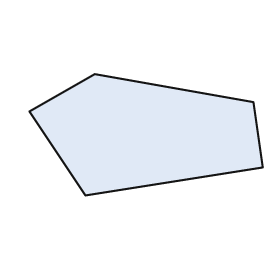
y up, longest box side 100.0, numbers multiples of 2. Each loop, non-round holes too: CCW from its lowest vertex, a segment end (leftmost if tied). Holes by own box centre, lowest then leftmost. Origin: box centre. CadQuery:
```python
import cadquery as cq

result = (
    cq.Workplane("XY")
    .moveTo(-26.0, -26.0)
    .lineTo(50.0, -14.0)
    .lineTo(46.0, 14.0)
    .lineTo(-22.0, 26.0)
    .lineTo(-50.0, 10.0)
    .close()
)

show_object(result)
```